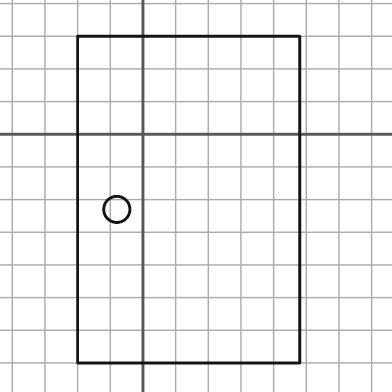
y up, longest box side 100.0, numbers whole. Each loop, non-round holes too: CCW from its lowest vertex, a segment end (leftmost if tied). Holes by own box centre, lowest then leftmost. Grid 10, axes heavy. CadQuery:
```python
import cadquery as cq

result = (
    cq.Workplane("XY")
    .moveTo(-20.0, -70.0)
    .lineTo(48.0, -70.0)
    .lineTo(48.0, 30.0)
    .lineTo(-20.0, 30.0)
    .close()
    .moveTo(-8.0, -23.0)
    .circle(4.0)
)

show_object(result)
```